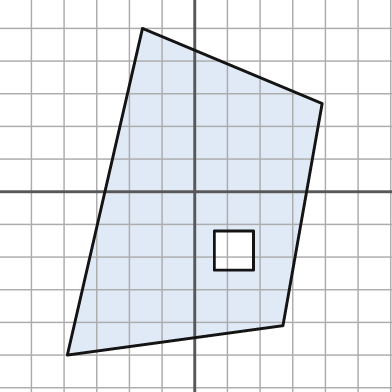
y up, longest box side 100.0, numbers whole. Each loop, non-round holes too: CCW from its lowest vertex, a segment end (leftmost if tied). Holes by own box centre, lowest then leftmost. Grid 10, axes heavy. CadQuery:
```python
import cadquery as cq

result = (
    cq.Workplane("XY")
    .moveTo(-39.0, -50.0)
    .lineTo(27.0, -41.0)
    .lineTo(39.0, 27.0)
    .lineTo(-16.0, 50.0)
    .close()
    .moveTo(6.0, -24.0)
    .lineTo(18.0, -24.0)
    .lineTo(18.0, -12.0)
    .lineTo(6.0, -12.0)
    .close()
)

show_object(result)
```